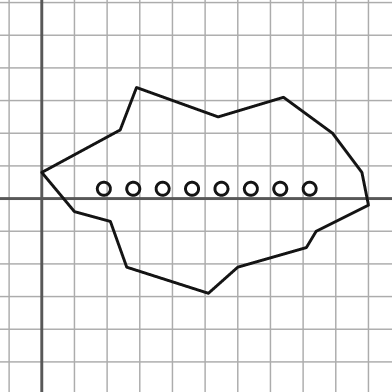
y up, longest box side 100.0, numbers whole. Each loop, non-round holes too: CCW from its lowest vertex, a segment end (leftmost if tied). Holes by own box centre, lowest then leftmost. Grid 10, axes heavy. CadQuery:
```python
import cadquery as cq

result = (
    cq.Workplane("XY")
    .moveTo(51.0, -29.0)
    .lineTo(60.0, -21.0)
    .lineTo(81.0, -15.0)
    .lineTo(84.0, -10.0)
    .lineTo(100.0, -2.0)
    .lineTo(98.0, 8.0)
    .lineTo(89.0, 20.0)
    .lineTo(74.0, 31.0)
    .lineTo(54.0, 25.0)
    .lineTo(29.0, 34.0)
    .lineTo(24.0, 21.0)
    .lineTo(0.0, 8.0)
    .lineTo(10.0, -4.0)
    .lineTo(21.0, -7.0)
    .lineTo(26.0, -21.0)
    .close()
    .moveTo(19.0, 3.0)
    .circle(2.0)
    .moveTo(28.0, 3.0)
    .circle(2.0)
    .moveTo(37.0, 3.0)
    .circle(2.0)
    .moveTo(46.0, 3.0)
    .circle(2.0)
    .moveTo(55.0, 3.0)
    .circle(2.0)
    .moveTo(64.0, 3.0)
    .circle(2.0)
    .moveTo(73.0, 3.0)
    .circle(2.0)
    .moveTo(82.0, 3.0)
    .circle(2.0)
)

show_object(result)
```